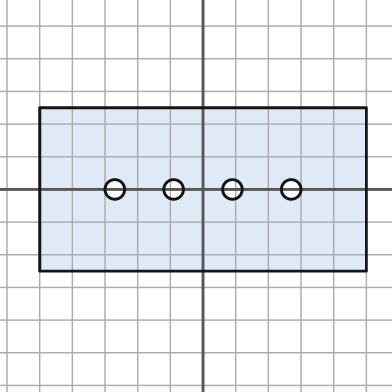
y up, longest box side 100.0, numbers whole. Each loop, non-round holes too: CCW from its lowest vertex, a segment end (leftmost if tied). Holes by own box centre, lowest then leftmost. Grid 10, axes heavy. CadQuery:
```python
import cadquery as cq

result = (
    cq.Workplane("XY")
    .moveTo(-50.0, -25.0)
    .lineTo(50.0, -25.0)
    .lineTo(50.0, 25.0)
    .lineTo(-50.0, 25.0)
    .close()
    .moveTo(-27.0, 0.0)
    .circle(3.0)
    .moveTo(-9.0, 0.0)
    .circle(3.0)
    .moveTo(9.0, 0.0)
    .circle(3.0)
    .moveTo(27.0, 0.0)
    .circle(3.0)
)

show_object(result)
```